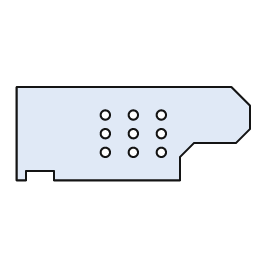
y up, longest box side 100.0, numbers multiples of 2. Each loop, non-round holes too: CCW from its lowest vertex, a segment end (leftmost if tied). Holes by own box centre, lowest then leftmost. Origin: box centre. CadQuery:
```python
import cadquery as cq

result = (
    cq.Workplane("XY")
    .moveTo(-50.0, -20.0)
    .lineTo(-46.0, -20.0)
    .lineTo(-46.0, -16.0)
    .lineTo(-34.0, -16.0)
    .lineTo(-34.0, -20.0)
    .lineTo(20.0, -20.0)
    .lineTo(20.0, -10.0)
    .lineTo(26.0, -4.0)
    .lineTo(44.0, -4.0)
    .lineTo(50.0, 2.0)
    .lineTo(50.0, 12.0)
    .lineTo(42.0, 20.0)
    .lineTo(-50.0, 20.0)
    .close()
    .moveTo(-12.0, -8.0)
    .circle(2.0)
    .moveTo(0.0, -8.0)
    .circle(2.0)
    .moveTo(12.0, -8.0)
    .circle(2.0)
    .moveTo(-12.0, 0.0)
    .circle(2.0)
    .moveTo(0.0, 0.0)
    .circle(2.0)
    .moveTo(12.0, 0.0)
    .circle(2.0)
    .moveTo(-12.0, 8.0)
    .circle(2.0)
    .moveTo(0.0, 8.0)
    .circle(2.0)
    .moveTo(12.0, 8.0)
    .circle(2.0)
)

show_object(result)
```